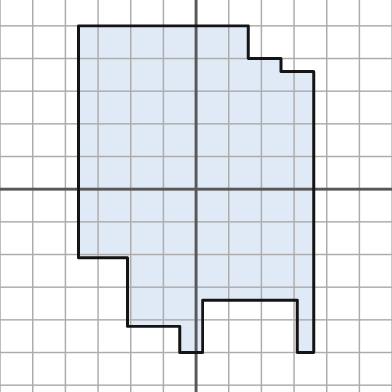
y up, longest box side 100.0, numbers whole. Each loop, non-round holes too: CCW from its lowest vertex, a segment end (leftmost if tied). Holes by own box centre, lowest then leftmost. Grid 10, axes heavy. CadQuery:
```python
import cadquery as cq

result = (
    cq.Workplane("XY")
    .moveTo(-5.0, -50.0)
    .lineTo(2.0, -50.0)
    .lineTo(2.0, -34.0)
    .lineTo(31.0, -34.0)
    .lineTo(31.0, -50.0)
    .lineTo(36.0, -50.0)
    .lineTo(36.0, 36.0)
    .lineTo(26.0, 36.0)
    .lineTo(26.0, 40.0)
    .lineTo(16.0, 40.0)
    .lineTo(16.0, 50.0)
    .lineTo(-36.0, 50.0)
    .lineTo(-36.0, -21.0)
    .lineTo(-21.0, -21.0)
    .lineTo(-21.0, -42.0)
    .lineTo(-5.0, -42.0)
    .close()
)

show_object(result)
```